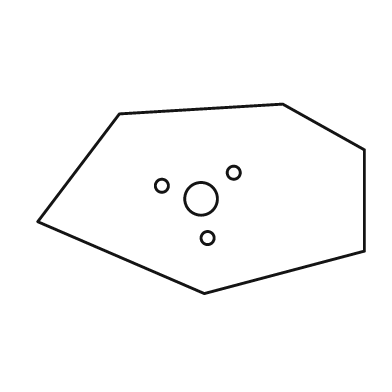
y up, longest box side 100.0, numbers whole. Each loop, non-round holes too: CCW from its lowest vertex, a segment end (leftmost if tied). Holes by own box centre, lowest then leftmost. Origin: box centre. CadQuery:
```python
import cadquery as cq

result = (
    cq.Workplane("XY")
    .moveTo(1.0, -29.0)
    .lineTo(50.0, -16.0)
    .lineTo(50.0, 15.0)
    .lineTo(25.0, 29.0)
    .lineTo(-25.0, 26.0)
    .lineTo(-50.0, -7.0)
    .close()
    .moveTo(2.0, -12.0)
    .circle(2.0)
    .moveTo(0.0, 0.0)
    .circle(5.0)
    .moveTo(-12.0, 4.0)
    .circle(2.0)
    .moveTo(10.0, 8.0)
    .circle(2.0)
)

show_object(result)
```